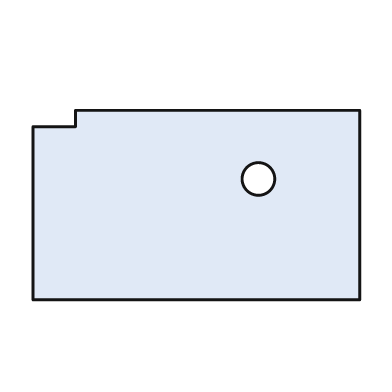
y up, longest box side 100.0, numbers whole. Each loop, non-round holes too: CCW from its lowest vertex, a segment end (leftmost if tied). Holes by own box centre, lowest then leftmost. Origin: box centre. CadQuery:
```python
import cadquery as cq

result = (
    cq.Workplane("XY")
    .moveTo(-50.0, -29.0)
    .lineTo(50.0, -29.0)
    .lineTo(50.0, 29.0)
    .lineTo(-37.0, 29.0)
    .lineTo(-37.0, 24.0)
    .lineTo(-50.0, 24.0)
    .close()
    .moveTo(19.0, 8.0)
    .circle(5.0)
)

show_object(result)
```